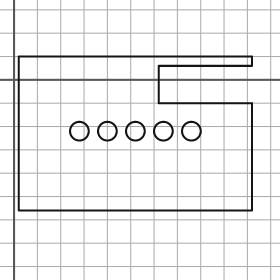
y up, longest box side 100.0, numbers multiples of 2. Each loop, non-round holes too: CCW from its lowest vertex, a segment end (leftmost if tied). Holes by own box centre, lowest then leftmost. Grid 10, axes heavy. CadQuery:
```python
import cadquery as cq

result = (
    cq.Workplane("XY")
    .moveTo(2.0, -56.0)
    .lineTo(102.0, -56.0)
    .lineTo(102.0, -10.0)
    .lineTo(62.0, -10.0)
    .lineTo(62.0, 6.0)
    .lineTo(102.0, 6.0)
    .lineTo(102.0, 10.0)
    .lineTo(2.0, 10.0)
    .close()
    .moveTo(28.0, -22.0)
    .circle(4.0)
    .moveTo(40.0, -22.0)
    .circle(4.0)
    .moveTo(52.0, -22.0)
    .circle(4.0)
    .moveTo(64.0, -22.0)
    .circle(4.0)
    .moveTo(76.0, -22.0)
    .circle(4.0)
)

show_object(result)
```